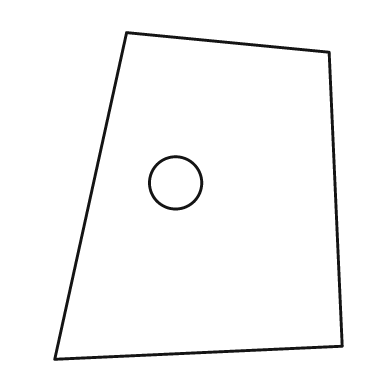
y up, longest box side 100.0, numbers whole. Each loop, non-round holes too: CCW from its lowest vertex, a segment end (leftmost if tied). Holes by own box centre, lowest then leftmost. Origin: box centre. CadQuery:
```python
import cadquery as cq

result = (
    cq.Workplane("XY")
    .moveTo(-44.0, -50.0)
    .lineTo(44.0, -46.0)
    .lineTo(40.0, 44.0)
    .lineTo(-22.0, 50.0)
    .close()
    .moveTo(-7.0, 4.0)
    .circle(8.0)
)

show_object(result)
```